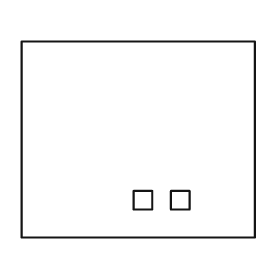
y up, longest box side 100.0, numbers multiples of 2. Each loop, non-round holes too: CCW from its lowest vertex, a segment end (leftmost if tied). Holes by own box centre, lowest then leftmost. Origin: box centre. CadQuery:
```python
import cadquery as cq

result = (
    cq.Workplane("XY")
    .moveTo(-50.0, -42.0)
    .lineTo(50.0, -42.0)
    .lineTo(50.0, 42.0)
    .lineTo(-50.0, 42.0)
    .close()
    .moveTo(-2.0, -30.0)
    .lineTo(6.0, -30.0)
    .lineTo(6.0, -22.0)
    .lineTo(-2.0, -22.0)
    .close()
    .moveTo(14.0, -30.0)
    .lineTo(22.0, -30.0)
    .lineTo(22.0, -22.0)
    .lineTo(14.0, -22.0)
    .close()
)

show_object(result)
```